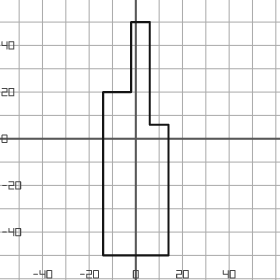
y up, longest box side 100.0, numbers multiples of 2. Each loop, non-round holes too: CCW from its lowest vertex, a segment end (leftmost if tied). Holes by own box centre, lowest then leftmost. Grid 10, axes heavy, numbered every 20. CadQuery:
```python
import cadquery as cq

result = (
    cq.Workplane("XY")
    .moveTo(-14.0, -50.0)
    .lineTo(14.0, -50.0)
    .lineTo(14.0, 6.0)
    .lineTo(6.0, 6.0)
    .lineTo(6.0, 50.0)
    .lineTo(-2.0, 50.0)
    .lineTo(-2.0, 20.0)
    .lineTo(-14.0, 20.0)
    .close()
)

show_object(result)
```